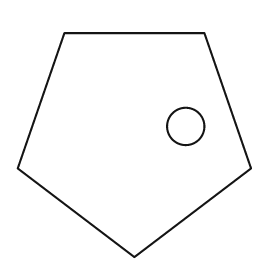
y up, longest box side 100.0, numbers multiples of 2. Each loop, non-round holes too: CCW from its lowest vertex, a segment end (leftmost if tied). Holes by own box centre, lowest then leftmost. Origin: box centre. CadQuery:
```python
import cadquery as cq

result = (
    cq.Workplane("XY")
    .moveTo(0.0, -48.0)
    .lineTo(50.0, -10.0)
    .lineTo(30.0, 48.0)
    .lineTo(-30.0, 48.0)
    .lineTo(-50.0, -10.0)
    .close()
    .moveTo(22.0, 8.0)
    .circle(8.0)
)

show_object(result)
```